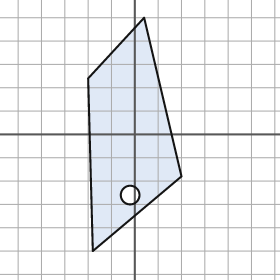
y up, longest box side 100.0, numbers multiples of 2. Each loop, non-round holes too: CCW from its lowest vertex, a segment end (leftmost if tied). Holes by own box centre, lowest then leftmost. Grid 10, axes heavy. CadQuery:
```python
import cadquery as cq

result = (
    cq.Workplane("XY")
    .moveTo(-18.0, -50.0)
    .lineTo(20.0, -18.0)
    .lineTo(4.0, 50.0)
    .lineTo(-20.0, 24.0)
    .close()
    .moveTo(-2.0, -26.0)
    .circle(4.0)
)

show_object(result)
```